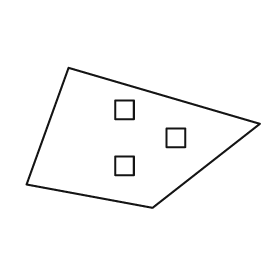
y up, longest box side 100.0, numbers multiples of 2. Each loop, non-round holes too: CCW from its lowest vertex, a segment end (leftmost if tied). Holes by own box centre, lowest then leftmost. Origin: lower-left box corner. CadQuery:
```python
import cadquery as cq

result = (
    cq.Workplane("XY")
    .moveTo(54.0, 0.0)
    .lineTo(100.0, 36.0)
    .lineTo(18.0, 60.0)
    .lineTo(0.0, 10.0)
    .close()
    .moveTo(38.0, 14.0)
    .lineTo(46.0, 14.0)
    .lineTo(46.0, 22.0)
    .lineTo(38.0, 22.0)
    .close()
    .moveTo(60.0, 26.0)
    .lineTo(68.0, 26.0)
    .lineTo(68.0, 34.0)
    .lineTo(60.0, 34.0)
    .close()
    .moveTo(38.0, 38.0)
    .lineTo(46.0, 38.0)
    .lineTo(46.0, 46.0)
    .lineTo(38.0, 46.0)
    .close()
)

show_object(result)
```